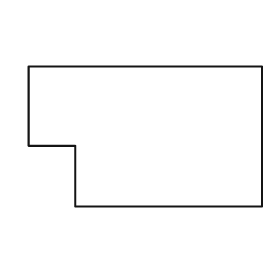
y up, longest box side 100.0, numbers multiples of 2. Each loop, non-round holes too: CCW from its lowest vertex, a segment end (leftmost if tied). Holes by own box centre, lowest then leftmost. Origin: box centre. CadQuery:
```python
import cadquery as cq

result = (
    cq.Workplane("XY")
    .moveTo(-30.0, -30.0)
    .lineTo(50.0, -30.0)
    .lineTo(50.0, 30.0)
    .lineTo(-50.0, 30.0)
    .lineTo(-50.0, -4.0)
    .lineTo(-30.0, -4.0)
    .close()
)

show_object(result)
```